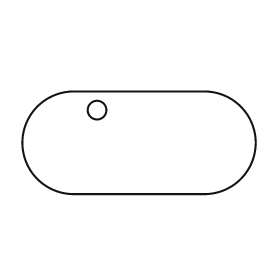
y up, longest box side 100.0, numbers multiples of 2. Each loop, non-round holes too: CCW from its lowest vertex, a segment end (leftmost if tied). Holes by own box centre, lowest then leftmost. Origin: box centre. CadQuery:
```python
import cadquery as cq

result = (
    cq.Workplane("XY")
    .moveTo(-28.0, -22.0)
    .lineTo(28.0, -22.0)
    .threePointArc((50.0, 0.0), (28.0, 22.0))
    .lineTo(-28.0, 22.0)
    .threePointArc((-50.0, 0.0), (-28.0, -22.0))
    .close()
    .moveTo(-18.0, 14.0)
    .circle(4.0)
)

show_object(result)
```